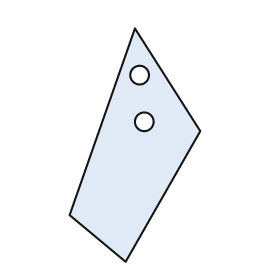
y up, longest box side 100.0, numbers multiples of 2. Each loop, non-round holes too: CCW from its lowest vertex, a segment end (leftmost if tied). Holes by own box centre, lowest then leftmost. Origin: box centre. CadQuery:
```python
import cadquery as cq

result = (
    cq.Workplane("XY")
    .moveTo(-4.0, -50.0)
    .lineTo(28.0, 6.0)
    .lineTo(0.0, 50.0)
    .lineTo(-28.0, -30.0)
    .close()
    .moveTo(4.0, 10.0)
    .circle(4.0)
    .moveTo(2.0, 30.0)
    .circle(4.0)
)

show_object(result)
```